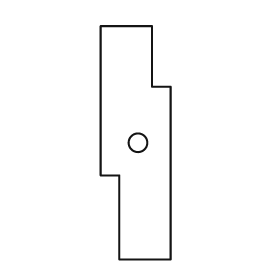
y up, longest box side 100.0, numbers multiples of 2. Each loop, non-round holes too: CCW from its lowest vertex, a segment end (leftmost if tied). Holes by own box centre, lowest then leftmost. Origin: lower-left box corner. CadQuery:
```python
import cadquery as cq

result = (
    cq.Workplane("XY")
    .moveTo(8.0, 0.0)
    .lineTo(30.0, 0.0)
    .lineTo(30.0, 74.0)
    .lineTo(22.0, 74.0)
    .lineTo(22.0, 100.0)
    .lineTo(0.0, 100.0)
    .lineTo(0.0, 36.0)
    .lineTo(8.0, 36.0)
    .close()
    .moveTo(16.0, 50.0)
    .circle(4.0)
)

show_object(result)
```